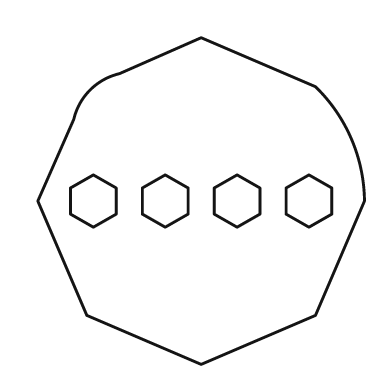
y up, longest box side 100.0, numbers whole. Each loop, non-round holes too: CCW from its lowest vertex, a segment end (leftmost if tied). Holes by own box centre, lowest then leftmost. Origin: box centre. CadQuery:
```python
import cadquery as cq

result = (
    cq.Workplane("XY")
    .moveTo(0.0, -50.0)
    .lineTo(35.0, -35.0)
    .lineTo(50.0, 0.0)
    .threePointArc((46.0, 19.0), (35.0, 35.0))
    .lineTo(0.0, 50.0)
    .lineTo(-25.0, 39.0)
    .threePointArc((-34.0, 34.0), (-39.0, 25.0))
    .lineTo(-50.0, 0.0)
    .lineTo(-35.0, -35.0)
    .close()
    .moveTo(-33.0, -8.0)
    .lineTo(-26.0, -4.0)
    .lineTo(-26.0, 4.0)
    .lineTo(-33.0, 8.0)
    .lineTo(-40.0, 4.0)
    .lineTo(-40.0, -4.0)
    .close()
    .moveTo(-11.0, -8.0)
    .lineTo(-4.0, -4.0)
    .lineTo(-4.0, 4.0)
    .lineTo(-11.0, 8.0)
    .lineTo(-18.0, 4.0)
    .lineTo(-18.0, -4.0)
    .close()
    .moveTo(11.0, -8.0)
    .lineTo(18.0, -4.0)
    .lineTo(18.0, 4.0)
    .lineTo(11.0, 8.0)
    .lineTo(4.0, 4.0)
    .lineTo(4.0, -4.0)
    .close()
    .moveTo(33.0, -8.0)
    .lineTo(40.0, -4.0)
    .lineTo(40.0, 4.0)
    .lineTo(33.0, 8.0)
    .lineTo(26.0, 4.0)
    .lineTo(26.0, -4.0)
    .close()
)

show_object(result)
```